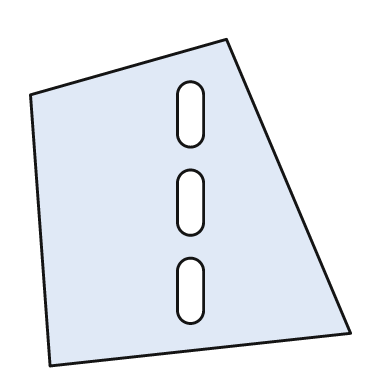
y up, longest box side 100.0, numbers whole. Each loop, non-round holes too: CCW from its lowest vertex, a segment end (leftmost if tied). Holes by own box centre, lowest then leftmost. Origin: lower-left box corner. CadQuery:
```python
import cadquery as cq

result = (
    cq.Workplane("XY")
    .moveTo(6.0, 0.0)
    .lineTo(98.0, 10.0)
    .lineTo(60.0, 100.0)
    .lineTo(0.0, 83.0)
    .close()
    .moveTo(45.0, 17.0)
    .threePointArc((49.0, 13.0), (53.0, 17.0))
    .lineTo(53.0, 29.0)
    .threePointArc((49.0, 33.0), (45.0, 29.0))
    .close()
    .moveTo(45.0, 44.0)
    .threePointArc((49.0, 40.0), (53.0, 44.0))
    .lineTo(53.0, 56.0)
    .threePointArc((49.0, 60.0), (45.0, 56.0))
    .close()
    .moveTo(45.0, 71.0)
    .threePointArc((49.0, 67.0), (53.0, 71.0))
    .lineTo(53.0, 83.0)
    .threePointArc((49.0, 87.0), (45.0, 83.0))
    .close()
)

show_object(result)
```